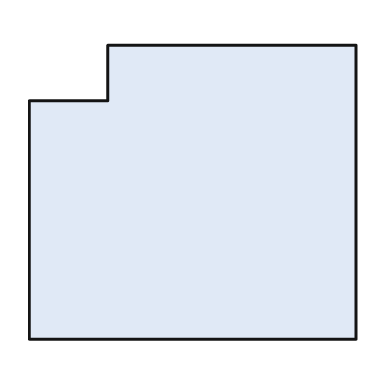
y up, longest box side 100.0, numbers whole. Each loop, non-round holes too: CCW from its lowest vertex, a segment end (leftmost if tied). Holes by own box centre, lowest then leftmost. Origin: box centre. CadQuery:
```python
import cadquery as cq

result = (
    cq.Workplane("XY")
    .moveTo(-50.0, -45.0)
    .lineTo(50.0, -45.0)
    .lineTo(50.0, 45.0)
    .lineTo(-26.0, 45.0)
    .lineTo(-26.0, 28.0)
    .lineTo(-50.0, 28.0)
    .close()
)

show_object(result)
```